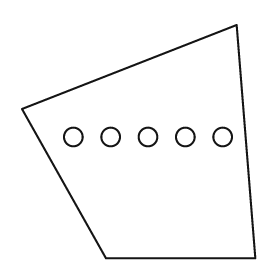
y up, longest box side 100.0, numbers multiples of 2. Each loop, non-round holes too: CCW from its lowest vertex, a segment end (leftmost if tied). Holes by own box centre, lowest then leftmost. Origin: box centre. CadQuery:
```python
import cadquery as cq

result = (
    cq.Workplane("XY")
    .moveTo(-14.0, -50.0)
    .lineTo(50.0, -50.0)
    .lineTo(42.0, 50.0)
    .lineTo(-50.0, 14.0)
    .close()
    .moveTo(-28.0, 2.0)
    .circle(4.0)
    .moveTo(-12.0, 2.0)
    .circle(4.0)
    .moveTo(4.0, 2.0)
    .circle(4.0)
    .moveTo(20.0, 2.0)
    .circle(4.0)
    .moveTo(36.0, 2.0)
    .circle(4.0)
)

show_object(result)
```